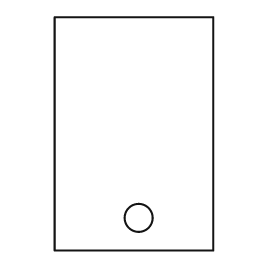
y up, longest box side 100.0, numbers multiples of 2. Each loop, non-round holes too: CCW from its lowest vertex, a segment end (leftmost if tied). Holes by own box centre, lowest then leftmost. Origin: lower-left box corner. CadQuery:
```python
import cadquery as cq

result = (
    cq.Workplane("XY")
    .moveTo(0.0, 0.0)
    .lineTo(68.0, 0.0)
    .lineTo(68.0, 100.0)
    .lineTo(0.0, 100.0)
    .close()
    .moveTo(36.0, 14.0)
    .circle(6.0)
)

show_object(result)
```